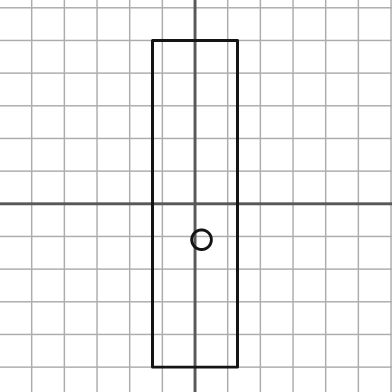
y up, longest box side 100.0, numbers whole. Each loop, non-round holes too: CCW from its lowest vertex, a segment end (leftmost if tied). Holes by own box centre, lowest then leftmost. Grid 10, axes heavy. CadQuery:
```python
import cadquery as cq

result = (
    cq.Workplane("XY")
    .moveTo(-13.0, -50.0)
    .lineTo(13.0, -50.0)
    .lineTo(13.0, 50.0)
    .lineTo(-13.0, 50.0)
    .close()
    .moveTo(2.0, -11.0)
    .circle(3.0)
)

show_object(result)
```